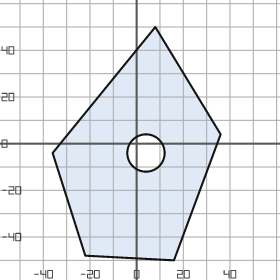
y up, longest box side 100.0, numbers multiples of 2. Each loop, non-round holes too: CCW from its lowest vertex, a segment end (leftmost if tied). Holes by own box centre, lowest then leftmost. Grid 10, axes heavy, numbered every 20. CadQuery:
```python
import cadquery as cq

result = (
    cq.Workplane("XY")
    .moveTo(16.0, -50.0)
    .lineTo(36.0, 4.0)
    .lineTo(8.0, 50.0)
    .lineTo(-36.0, -4.0)
    .lineTo(-22.0, -48.0)
    .close()
    .moveTo(4.0, -4.0)
    .circle(8.0)
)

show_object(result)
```